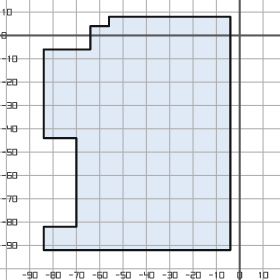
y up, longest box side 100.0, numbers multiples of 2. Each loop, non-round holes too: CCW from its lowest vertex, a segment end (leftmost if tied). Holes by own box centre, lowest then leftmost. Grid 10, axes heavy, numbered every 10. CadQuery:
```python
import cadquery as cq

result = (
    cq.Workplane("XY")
    .moveTo(-84.0, -92.0)
    .lineTo(-4.0, -92.0)
    .lineTo(-4.0, 8.0)
    .lineTo(-56.0, 8.0)
    .lineTo(-56.0, 4.0)
    .lineTo(-64.0, 4.0)
    .lineTo(-64.0, -6.0)
    .lineTo(-84.0, -6.0)
    .lineTo(-84.0, -44.0)
    .lineTo(-70.0, -44.0)
    .lineTo(-70.0, -82.0)
    .lineTo(-84.0, -82.0)
    .close()
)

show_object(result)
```